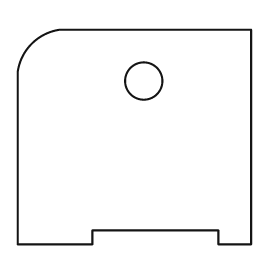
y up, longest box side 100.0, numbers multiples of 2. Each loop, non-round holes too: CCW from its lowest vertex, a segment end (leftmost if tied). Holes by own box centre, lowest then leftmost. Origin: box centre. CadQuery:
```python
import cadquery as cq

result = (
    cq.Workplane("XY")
    .moveTo(-50.0, -46.0)
    .lineTo(-18.0, -46.0)
    .lineTo(-18.0, -40.0)
    .lineTo(36.0, -40.0)
    .lineTo(36.0, -46.0)
    .lineTo(50.0, -46.0)
    .lineTo(50.0, 46.0)
    .lineTo(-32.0, 46.0)
    .threePointArc((-44.0, 40.0), (-50.0, 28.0))
    .close()
    .moveTo(4.0, 24.0)
    .circle(8.0)
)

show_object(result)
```